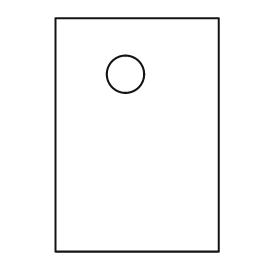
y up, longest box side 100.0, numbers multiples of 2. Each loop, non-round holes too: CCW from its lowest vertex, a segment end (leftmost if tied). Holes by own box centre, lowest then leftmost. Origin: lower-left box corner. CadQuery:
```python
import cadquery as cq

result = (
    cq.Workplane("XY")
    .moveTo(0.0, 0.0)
    .lineTo(70.0, 0.0)
    .lineTo(70.0, 100.0)
    .lineTo(0.0, 100.0)
    .close()
    .moveTo(30.0, 76.0)
    .circle(8.0)
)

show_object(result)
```